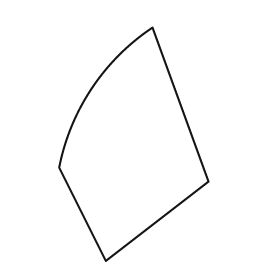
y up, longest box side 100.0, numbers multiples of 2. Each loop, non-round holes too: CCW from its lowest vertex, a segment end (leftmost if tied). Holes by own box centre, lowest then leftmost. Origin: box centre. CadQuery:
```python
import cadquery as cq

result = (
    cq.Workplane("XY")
    .moveTo(-12.0, -50.0)
    .lineTo(32.0, -16.0)
    .lineTo(8.0, 50.0)
    .threePointArc((-18.0, 24.0), (-32.0, -10.0))
    .close()
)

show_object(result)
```